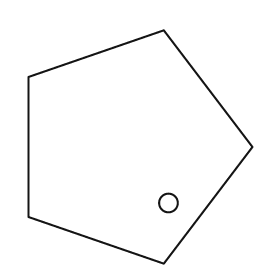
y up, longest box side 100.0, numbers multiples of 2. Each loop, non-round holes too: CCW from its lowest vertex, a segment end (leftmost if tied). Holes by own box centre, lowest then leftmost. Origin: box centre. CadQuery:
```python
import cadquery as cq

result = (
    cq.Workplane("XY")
    .moveTo(10.0, -50.0)
    .lineTo(48.0, 0.0)
    .lineTo(10.0, 50.0)
    .lineTo(-48.0, 30.0)
    .lineTo(-48.0, -30.0)
    .close()
    .moveTo(12.0, -24.0)
    .circle(4.0)
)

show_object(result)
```